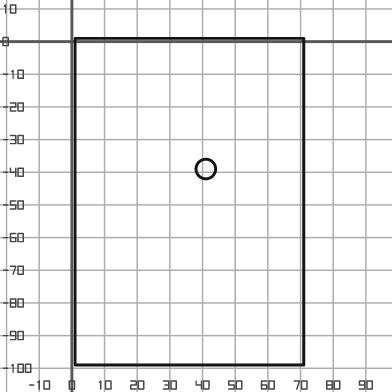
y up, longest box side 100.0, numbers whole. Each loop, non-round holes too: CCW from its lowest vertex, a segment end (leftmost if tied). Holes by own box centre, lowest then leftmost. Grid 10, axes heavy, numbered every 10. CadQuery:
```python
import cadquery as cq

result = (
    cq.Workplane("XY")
    .moveTo(1.0, -99.0)
    .lineTo(71.0, -99.0)
    .lineTo(71.0, 1.0)
    .lineTo(1.0, 1.0)
    .close()
    .moveTo(41.0, -39.0)
    .circle(3.0)
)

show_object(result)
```